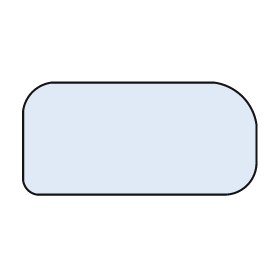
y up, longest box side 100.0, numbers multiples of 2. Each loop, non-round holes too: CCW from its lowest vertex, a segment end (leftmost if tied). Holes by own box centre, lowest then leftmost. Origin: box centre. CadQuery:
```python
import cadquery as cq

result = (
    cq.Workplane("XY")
    .moveTo(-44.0, -24.0)
    .lineTo(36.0, -24.0)
    .threePointArc((46.0, -20.0), (50.0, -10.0))
    .lineTo(50.0, 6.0)
    .threePointArc((44.0, 18.0), (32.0, 24.0))
    .lineTo(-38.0, 24.0)
    .threePointArc((-46.0, 20.0), (-50.0, 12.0))
    .lineTo(-50.0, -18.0)
    .threePointArc((-48.0, -22.0), (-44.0, -24.0))
    .close()
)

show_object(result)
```